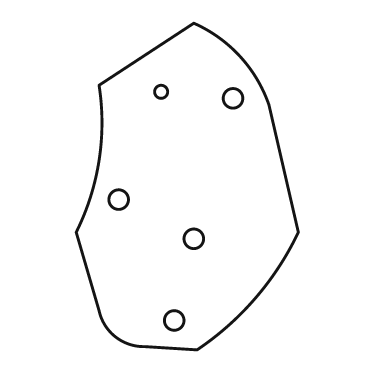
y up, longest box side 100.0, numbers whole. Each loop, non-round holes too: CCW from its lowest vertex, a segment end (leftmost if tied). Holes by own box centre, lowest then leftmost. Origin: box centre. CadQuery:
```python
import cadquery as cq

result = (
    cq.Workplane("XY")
    .moveTo(3.0, -50.0)
    .threePointArc((21.0, -34.0), (34.0, -14.0))
    .lineTo(25.0, 25.0)
    .threePointArc((16.0, 40.0), (2.0, 50.0))
    .lineTo(-27.0, 31.0)
    .threePointArc((-27.0, 8.0), (-34.0, -14.0))
    .lineTo(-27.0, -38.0)
    .threePointArc((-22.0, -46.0), (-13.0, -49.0))
    .close()
    .moveTo(-4.0, -41.0)
    .circle(3.0)
    .moveTo(2.0, -16.0)
    .circle(3.0)
    .moveTo(-21.0, -4.0)
    .circle(3.0)
    .moveTo(14.0, 27.0)
    .circle(3.0)
    .moveTo(-8.0, 29.0)
    .circle(2.0)
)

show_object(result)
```